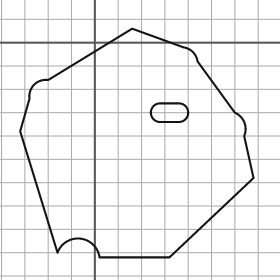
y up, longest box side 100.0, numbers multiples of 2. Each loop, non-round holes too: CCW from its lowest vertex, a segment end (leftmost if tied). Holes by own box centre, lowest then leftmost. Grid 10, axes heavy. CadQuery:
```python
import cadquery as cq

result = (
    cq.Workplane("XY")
    .moveTo(2.0, -92.0)
    .lineTo(32.0, -92.0)
    .lineTo(68.0, -58.0)
    .lineTo(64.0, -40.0)
    .threePointArc((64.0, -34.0), (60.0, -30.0))
    .lineTo(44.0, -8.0)
    .threePointArc((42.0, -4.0), (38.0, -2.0))
    .lineTo(16.0, 6.0)
    .lineTo(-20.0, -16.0)
    .threePointArc((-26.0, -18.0), (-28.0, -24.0))
    .lineTo(-32.0, -38.0)
    .lineTo(-16.0, -90.0)
    .threePointArc((-6.0, -84.0), (2.0, -92.0))
    .close()
    .moveTo(28.0, -34.0)
    .lineTo(36.0, -34.0)
    .threePointArc((40.0, -30.0), (36.0, -26.0))
    .lineTo(28.0, -26.0)
    .threePointArc((24.0, -30.0), (28.0, -34.0))
    .close()
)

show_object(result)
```